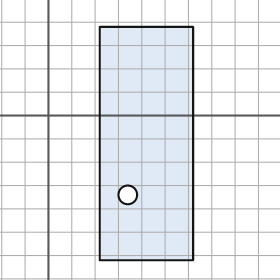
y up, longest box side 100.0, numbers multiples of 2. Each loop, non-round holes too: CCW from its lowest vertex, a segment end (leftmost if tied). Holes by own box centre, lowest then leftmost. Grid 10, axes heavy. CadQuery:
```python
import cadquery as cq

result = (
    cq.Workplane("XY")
    .moveTo(22.0, -62.0)
    .lineTo(62.0, -62.0)
    .lineTo(62.0, 38.0)
    .lineTo(22.0, 38.0)
    .close()
    .moveTo(34.0, -34.0)
    .circle(4.0)
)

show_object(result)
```